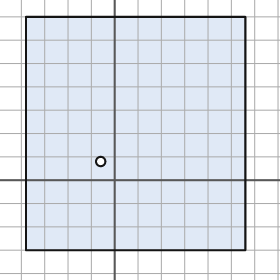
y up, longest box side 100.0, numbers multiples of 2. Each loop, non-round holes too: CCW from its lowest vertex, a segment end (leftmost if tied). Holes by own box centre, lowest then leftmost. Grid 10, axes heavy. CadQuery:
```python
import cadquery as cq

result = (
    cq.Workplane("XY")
    .moveTo(-38.0, -30.0)
    .lineTo(56.0, -30.0)
    .lineTo(56.0, 70.0)
    .lineTo(-38.0, 70.0)
    .close()
    .moveTo(-6.0, 8.0)
    .circle(2.0)
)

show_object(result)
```